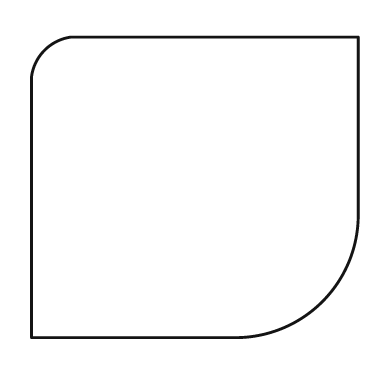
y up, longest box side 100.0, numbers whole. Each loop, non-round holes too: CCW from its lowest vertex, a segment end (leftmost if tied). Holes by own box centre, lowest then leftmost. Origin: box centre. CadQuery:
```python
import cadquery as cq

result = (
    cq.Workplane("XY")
    .moveTo(-50.0, -46.0)
    .lineTo(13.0, -46.0)
    .threePointArc((39.0, -35.0), (50.0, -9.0))
    .lineTo(50.0, 46.0)
    .lineTo(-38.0, 46.0)
    .threePointArc((-46.0, 42.0), (-50.0, 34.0))
    .close()
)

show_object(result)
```